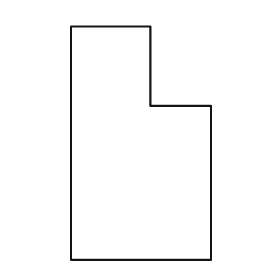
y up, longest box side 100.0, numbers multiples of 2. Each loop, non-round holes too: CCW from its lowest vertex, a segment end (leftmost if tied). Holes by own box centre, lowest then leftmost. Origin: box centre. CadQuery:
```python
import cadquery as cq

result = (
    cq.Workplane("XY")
    .moveTo(-30.0, -50.0)
    .lineTo(30.0, -50.0)
    .lineTo(30.0, 16.0)
    .lineTo(4.0, 16.0)
    .lineTo(4.0, 50.0)
    .lineTo(-30.0, 50.0)
    .close()
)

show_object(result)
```